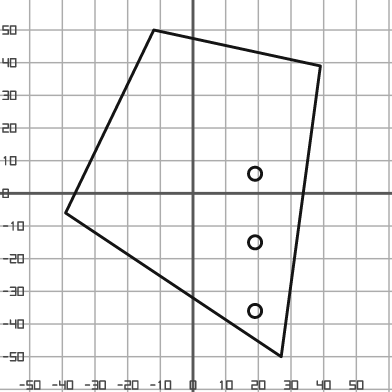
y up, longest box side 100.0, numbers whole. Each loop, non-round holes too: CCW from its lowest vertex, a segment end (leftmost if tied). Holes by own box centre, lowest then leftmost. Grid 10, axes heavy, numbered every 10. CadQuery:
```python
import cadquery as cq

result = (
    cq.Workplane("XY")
    .moveTo(27.0, -50.0)
    .lineTo(39.0, 39.0)
    .lineTo(-12.0, 50.0)
    .lineTo(-39.0, -6.0)
    .close()
    .moveTo(19.0, -36.0)
    .circle(2.0)
    .moveTo(19.0, -15.0)
    .circle(2.0)
    .moveTo(19.0, 6.0)
    .circle(2.0)
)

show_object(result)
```